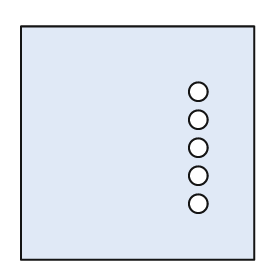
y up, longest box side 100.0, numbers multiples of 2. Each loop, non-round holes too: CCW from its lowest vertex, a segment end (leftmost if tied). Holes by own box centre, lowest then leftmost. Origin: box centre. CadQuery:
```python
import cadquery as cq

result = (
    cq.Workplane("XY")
    .moveTo(-50.0, -50.0)
    .lineTo(50.0, -50.0)
    .lineTo(50.0, 50.0)
    .lineTo(-50.0, 50.0)
    .close()
    .moveTo(26.0, -26.0)
    .circle(4.0)
    .moveTo(26.0, -14.0)
    .circle(4.0)
    .moveTo(26.0, -2.0)
    .circle(4.0)
    .moveTo(26.0, 10.0)
    .circle(4.0)
    .moveTo(26.0, 22.0)
    .circle(4.0)
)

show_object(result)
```